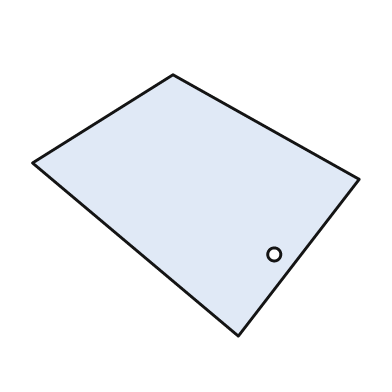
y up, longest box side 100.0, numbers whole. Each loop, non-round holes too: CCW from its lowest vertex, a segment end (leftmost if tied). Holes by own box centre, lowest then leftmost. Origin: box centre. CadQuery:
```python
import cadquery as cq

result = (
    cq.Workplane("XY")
    .moveTo(13.0, -40.0)
    .lineTo(50.0, 8.0)
    .lineTo(-7.0, 40.0)
    .lineTo(-50.0, 13.0)
    .close()
    .moveTo(24.0, -15.0)
    .circle(2.0)
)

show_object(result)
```